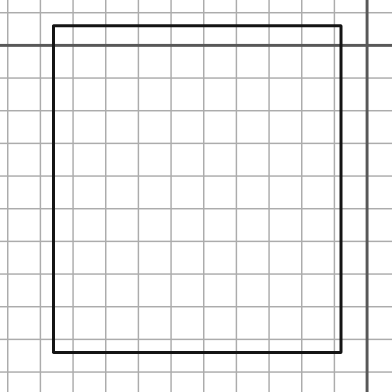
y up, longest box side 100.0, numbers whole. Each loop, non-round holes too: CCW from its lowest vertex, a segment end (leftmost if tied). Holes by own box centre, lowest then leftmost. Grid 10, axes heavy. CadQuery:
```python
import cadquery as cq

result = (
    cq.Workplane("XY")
    .moveTo(-96.0, -94.0)
    .lineTo(-8.0, -94.0)
    .lineTo(-8.0, 6.0)
    .lineTo(-96.0, 6.0)
    .close()
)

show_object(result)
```